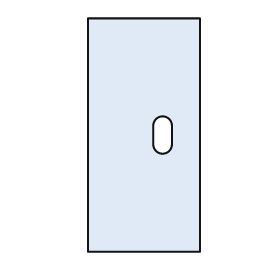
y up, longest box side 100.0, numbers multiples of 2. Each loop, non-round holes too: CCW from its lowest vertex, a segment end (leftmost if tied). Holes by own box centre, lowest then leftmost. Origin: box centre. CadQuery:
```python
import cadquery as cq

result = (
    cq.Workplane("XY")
    .moveTo(-24.0, -50.0)
    .lineTo(24.0, -50.0)
    .lineTo(24.0, 50.0)
    .lineTo(-24.0, 50.0)
    .close()
    .moveTo(4.0, -4.0)
    .threePointArc((8.0, -8.0), (12.0, -4.0))
    .lineTo(12.0, 4.0)
    .threePointArc((8.0, 8.0), (4.0, 4.0))
    .close()
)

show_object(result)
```